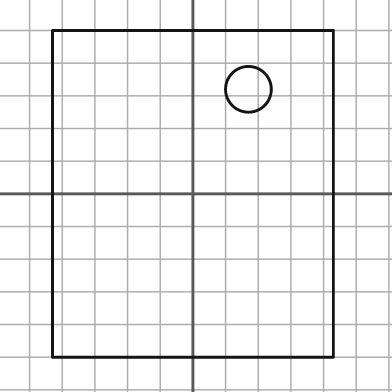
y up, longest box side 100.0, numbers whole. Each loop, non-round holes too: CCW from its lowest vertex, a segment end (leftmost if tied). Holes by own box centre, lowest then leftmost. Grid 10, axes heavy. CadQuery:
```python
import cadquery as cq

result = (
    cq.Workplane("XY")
    .moveTo(-43.0, -50.0)
    .lineTo(43.0, -50.0)
    .lineTo(43.0, 50.0)
    .lineTo(-43.0, 50.0)
    .close()
    .moveTo(17.0, 32.0)
    .circle(7.0)
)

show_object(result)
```